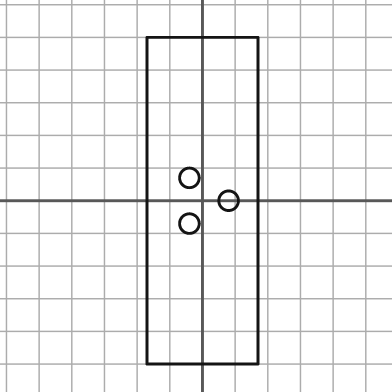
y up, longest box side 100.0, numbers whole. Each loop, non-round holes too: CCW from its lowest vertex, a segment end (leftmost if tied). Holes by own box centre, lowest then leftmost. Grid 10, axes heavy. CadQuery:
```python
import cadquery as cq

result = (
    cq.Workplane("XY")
    .moveTo(-17.0, -50.0)
    .lineTo(17.0, -50.0)
    .lineTo(17.0, 50.0)
    .lineTo(-17.0, 50.0)
    .close()
    .moveTo(-4.0, -7.0)
    .circle(3.0)
    .moveTo(8.0, 0.0)
    .circle(3.0)
    .moveTo(-4.0, 7.0)
    .circle(3.0)
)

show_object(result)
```